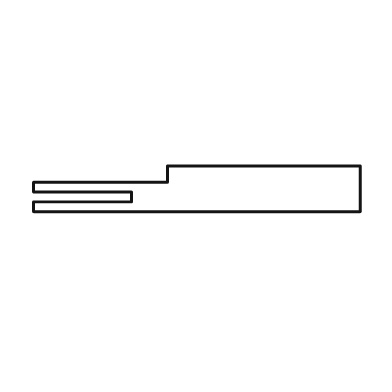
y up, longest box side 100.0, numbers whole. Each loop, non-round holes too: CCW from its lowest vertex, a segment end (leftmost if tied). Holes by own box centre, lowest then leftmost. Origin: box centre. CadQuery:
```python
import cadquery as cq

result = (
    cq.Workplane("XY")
    .moveTo(-50.0, -7.0)
    .lineTo(50.0, -7.0)
    .lineTo(50.0, 7.0)
    .lineTo(-9.0, 7.0)
    .lineTo(-9.0, 2.0)
    .lineTo(-50.0, 2.0)
    .lineTo(-50.0, -1.0)
    .lineTo(-20.0, -1.0)
    .lineTo(-20.0, -4.0)
    .lineTo(-50.0, -4.0)
    .close()
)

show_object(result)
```